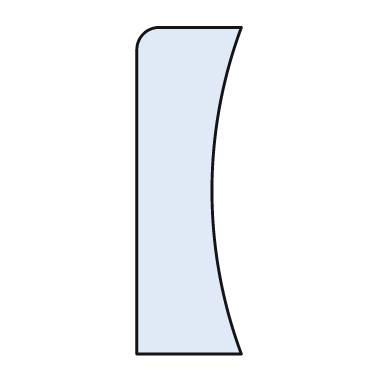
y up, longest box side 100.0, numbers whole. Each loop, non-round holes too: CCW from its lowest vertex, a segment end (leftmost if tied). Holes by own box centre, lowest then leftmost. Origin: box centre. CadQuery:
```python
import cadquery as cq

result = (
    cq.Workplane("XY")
    .moveTo(-16.0, -50.0)
    .lineTo(16.0, -50.0)
    .threePointArc((7.0, 0.0), (16.0, 50.0))
    .lineTo(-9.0, 50.0)
    .threePointArc((-14.0, 48.0), (-16.0, 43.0))
    .close()
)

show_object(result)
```